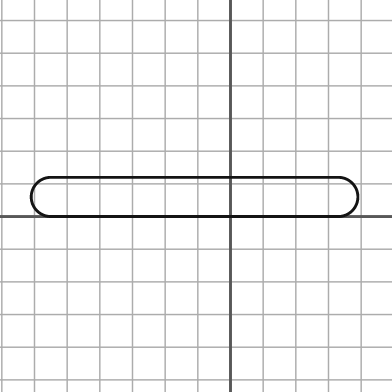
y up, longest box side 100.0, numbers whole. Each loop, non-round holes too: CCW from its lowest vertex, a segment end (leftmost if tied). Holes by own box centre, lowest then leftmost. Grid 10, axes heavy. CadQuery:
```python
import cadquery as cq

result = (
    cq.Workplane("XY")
    .moveTo(-55.0, 0.0)
    .lineTo(33.0, 0.0)
    .threePointArc((39.0, 6.0), (33.0, 12.0))
    .lineTo(-55.0, 12.0)
    .threePointArc((-61.0, 6.0), (-55.0, 0.0))
    .close()
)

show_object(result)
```